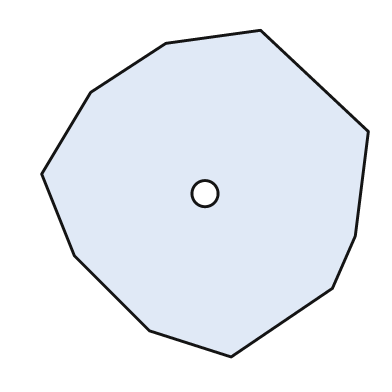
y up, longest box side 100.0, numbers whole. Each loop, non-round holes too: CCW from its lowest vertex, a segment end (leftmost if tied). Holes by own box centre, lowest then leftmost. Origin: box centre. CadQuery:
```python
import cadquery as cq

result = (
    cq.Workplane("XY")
    .moveTo(8.0, -50.0)
    .lineTo(39.0, -29.0)
    .lineTo(46.0, -13.0)
    .lineTo(50.0, 19.0)
    .lineTo(17.0, 50.0)
    .lineTo(-12.0, 46.0)
    .lineTo(-35.0, 31.0)
    .lineTo(-50.0, 6.0)
    .lineTo(-40.0, -19.0)
    .lineTo(-17.0, -42.0)
    .close()
    .moveTo(0.0, 0.0)
    .circle(4.0)
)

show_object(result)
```